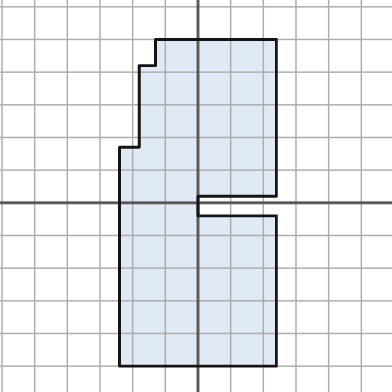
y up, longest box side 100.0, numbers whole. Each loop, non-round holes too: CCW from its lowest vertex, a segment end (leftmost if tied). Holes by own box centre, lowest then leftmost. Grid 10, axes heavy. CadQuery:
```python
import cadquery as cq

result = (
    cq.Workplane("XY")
    .moveTo(-24.0, -50.0)
    .lineTo(24.0, -50.0)
    .lineTo(24.0, -4.0)
    .lineTo(0.0, -4.0)
    .lineTo(0.0, 2.0)
    .lineTo(24.0, 2.0)
    .lineTo(24.0, 50.0)
    .lineTo(-13.0, 50.0)
    .lineTo(-13.0, 42.0)
    .lineTo(-18.0, 42.0)
    .lineTo(-18.0, 17.0)
    .lineTo(-24.0, 17.0)
    .close()
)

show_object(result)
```